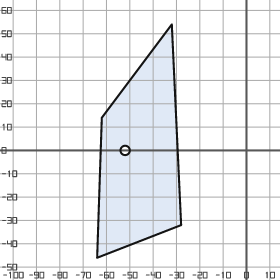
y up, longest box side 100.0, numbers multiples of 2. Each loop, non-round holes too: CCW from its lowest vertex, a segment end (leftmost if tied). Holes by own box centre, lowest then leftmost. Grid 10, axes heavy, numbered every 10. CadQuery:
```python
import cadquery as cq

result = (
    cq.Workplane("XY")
    .moveTo(-64.0, -46.0)
    .lineTo(-28.0, -32.0)
    .lineTo(-32.0, 54.0)
    .lineTo(-62.0, 14.0)
    .close()
    .moveTo(-52.0, 0.0)
    .circle(2.0)
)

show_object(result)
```